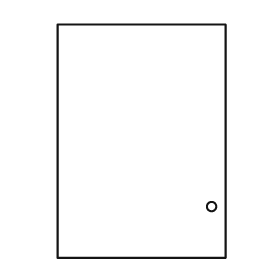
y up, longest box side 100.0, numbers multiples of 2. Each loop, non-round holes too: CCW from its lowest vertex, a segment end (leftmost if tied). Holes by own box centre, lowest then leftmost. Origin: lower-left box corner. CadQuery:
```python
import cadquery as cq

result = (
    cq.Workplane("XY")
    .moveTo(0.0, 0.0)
    .lineTo(72.0, 0.0)
    .lineTo(72.0, 100.0)
    .lineTo(0.0, 100.0)
    .close()
    .moveTo(66.0, 22.0)
    .circle(2.0)
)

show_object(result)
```